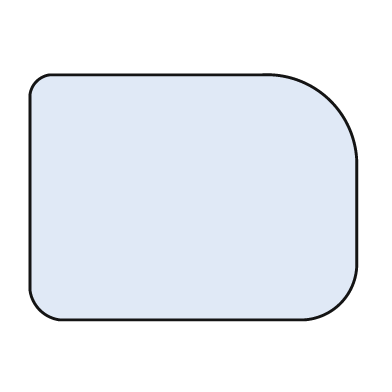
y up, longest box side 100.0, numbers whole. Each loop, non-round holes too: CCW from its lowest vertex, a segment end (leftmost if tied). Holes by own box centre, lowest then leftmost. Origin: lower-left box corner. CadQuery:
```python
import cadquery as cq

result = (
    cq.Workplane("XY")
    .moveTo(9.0, 0.0)
    .lineTo(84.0, 0.0)
    .threePointArc((95.0, 5.0), (100.0, 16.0))
    .lineTo(100.0, 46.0)
    .threePointArc((92.0, 67.0), (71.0, 75.0))
    .lineTo(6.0, 75.0)
    .threePointArc((2.0, 73.0), (0.0, 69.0))
    .lineTo(0.0, 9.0)
    .threePointArc((3.0, 3.0), (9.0, 0.0))
    .close()
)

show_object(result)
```